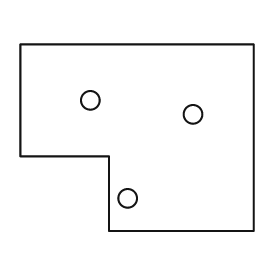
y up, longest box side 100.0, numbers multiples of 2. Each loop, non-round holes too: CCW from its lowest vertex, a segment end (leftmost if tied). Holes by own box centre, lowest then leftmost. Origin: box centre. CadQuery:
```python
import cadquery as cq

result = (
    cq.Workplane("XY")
    .moveTo(-12.0, -40.0)
    .lineTo(50.0, -40.0)
    .lineTo(50.0, 40.0)
    .lineTo(-50.0, 40.0)
    .lineTo(-50.0, -8.0)
    .lineTo(-12.0, -8.0)
    .close()
    .moveTo(-4.0, -26.0)
    .circle(4.0)
    .moveTo(24.0, 10.0)
    .circle(4.0)
    .moveTo(-20.0, 16.0)
    .circle(4.0)
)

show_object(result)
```